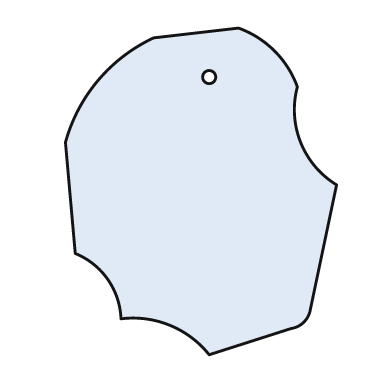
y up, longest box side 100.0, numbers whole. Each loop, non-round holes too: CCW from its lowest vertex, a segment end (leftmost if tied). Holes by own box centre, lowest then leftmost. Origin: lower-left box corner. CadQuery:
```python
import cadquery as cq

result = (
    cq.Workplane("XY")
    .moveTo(44.0, 0.0)
    .lineTo(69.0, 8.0)
    .threePointArc((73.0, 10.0), (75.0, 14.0))
    .lineTo(83.0, 52.0)
    .threePointArc((72.0, 65.0), (71.0, 82.0))
    .threePointArc((64.0, 93.0), (53.0, 100.0))
    .lineTo(27.0, 97.0)
    .threePointArc((10.0, 84.0), (0.0, 65.0))
    .lineTo(3.0, 31.0)
    .threePointArc((13.0, 23.0), (17.0, 11.0))
    .threePointArc((32.0, 9.0), (44.0, 0.0))
    .close()
    .moveTo(44.0, 85.0)
    .circle(2.0)
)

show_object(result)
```